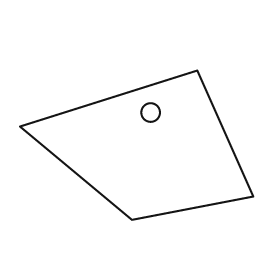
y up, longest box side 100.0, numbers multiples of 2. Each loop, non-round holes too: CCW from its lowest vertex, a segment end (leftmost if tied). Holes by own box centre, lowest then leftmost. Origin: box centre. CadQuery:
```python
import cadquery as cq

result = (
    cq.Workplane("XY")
    .moveTo(-2.0, -32.0)
    .lineTo(50.0, -22.0)
    .lineTo(26.0, 32.0)
    .lineTo(-50.0, 8.0)
    .close()
    .moveTo(6.0, 14.0)
    .circle(4.0)
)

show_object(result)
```